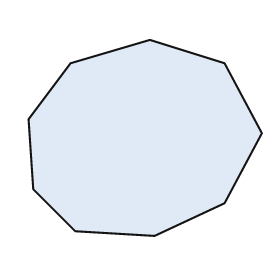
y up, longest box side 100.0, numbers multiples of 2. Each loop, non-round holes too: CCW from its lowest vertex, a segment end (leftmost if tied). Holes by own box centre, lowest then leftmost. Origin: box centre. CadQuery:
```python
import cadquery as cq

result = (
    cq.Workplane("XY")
    .moveTo(4.0, -42.0)
    .lineTo(34.0, -28.0)
    .lineTo(50.0, 2.0)
    .lineTo(34.0, 32.0)
    .lineTo(2.0, 42.0)
    .lineTo(-32.0, 32.0)
    .lineTo(-50.0, 8.0)
    .lineTo(-48.0, -22.0)
    .lineTo(-30.0, -40.0)
    .close()
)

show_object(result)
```